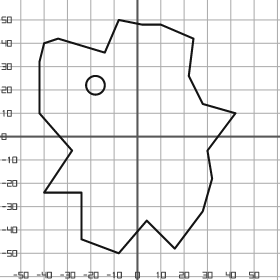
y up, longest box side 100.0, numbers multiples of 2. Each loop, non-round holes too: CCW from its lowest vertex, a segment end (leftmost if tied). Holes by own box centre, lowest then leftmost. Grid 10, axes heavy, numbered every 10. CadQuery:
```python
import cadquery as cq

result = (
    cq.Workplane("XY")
    .moveTo(-8.0, -50.0)
    .lineTo(4.0, -36.0)
    .lineTo(16.0, -48.0)
    .lineTo(28.0, -32.0)
    .lineTo(32.0, -18.0)
    .lineTo(30.0, -6.0)
    .lineTo(42.0, 10.0)
    .lineTo(28.0, 14.0)
    .lineTo(22.0, 26.0)
    .lineTo(24.0, 42.0)
    .lineTo(10.0, 48.0)
    .lineTo(2.0, 48.0)
    .lineTo(-8.0, 50.0)
    .lineTo(-14.0, 36.0)
    .lineTo(-34.0, 42.0)
    .lineTo(-40.0, 40.0)
    .lineTo(-42.0, 32.0)
    .lineTo(-42.0, 10.0)
    .lineTo(-28.0, -6.0)
    .lineTo(-40.0, -24.0)
    .lineTo(-24.0, -24.0)
    .lineTo(-24.0, -44.0)
    .close()
    .moveTo(-18.0, 22.0)
    .circle(4.0)
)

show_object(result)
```